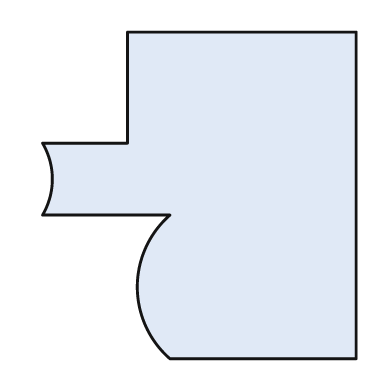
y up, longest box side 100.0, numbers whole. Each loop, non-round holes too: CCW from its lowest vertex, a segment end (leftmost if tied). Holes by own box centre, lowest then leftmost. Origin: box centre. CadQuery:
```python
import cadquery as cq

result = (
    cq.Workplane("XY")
    .moveTo(-9.0, -50.0)
    .lineTo(48.0, -50.0)
    .lineTo(48.0, 50.0)
    .lineTo(-22.0, 50.0)
    .lineTo(-22.0, 16.0)
    .lineTo(-48.0, 16.0)
    .threePointArc((-45.0, 5.0), (-48.0, -6.0))
    .lineTo(-9.0, -6.0)
    .threePointArc((-19.0, -28.0), (-9.0, -50.0))
    .close()
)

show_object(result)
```